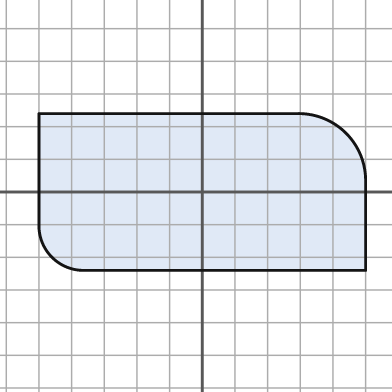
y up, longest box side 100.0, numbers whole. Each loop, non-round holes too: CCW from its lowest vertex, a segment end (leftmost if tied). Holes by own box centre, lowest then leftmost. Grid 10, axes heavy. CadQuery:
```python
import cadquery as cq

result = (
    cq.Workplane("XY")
    .moveTo(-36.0, -24.0)
    .lineTo(50.0, -24.0)
    .lineTo(50.0, 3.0)
    .threePointArc((44.0, 18.0), (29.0, 24.0))
    .lineTo(-50.0, 24.0)
    .lineTo(-50.0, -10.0)
    .threePointArc((-46.0, -20.0), (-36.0, -24.0))
    .close()
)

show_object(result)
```